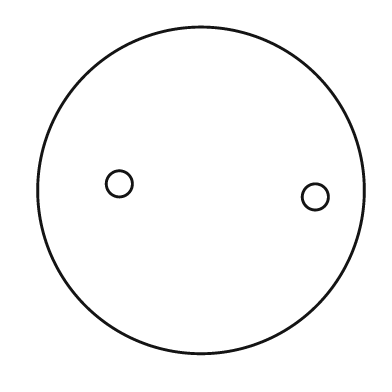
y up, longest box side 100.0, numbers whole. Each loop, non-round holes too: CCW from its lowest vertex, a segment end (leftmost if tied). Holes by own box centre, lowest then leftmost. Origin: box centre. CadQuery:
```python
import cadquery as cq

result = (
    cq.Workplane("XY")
    .moveTo(0.0, 0.0)
    .circle(50.0)
    .moveTo(35.0, -2.0)
    .circle(4.0)
    .moveTo(-25.0, 2.0)
    .circle(4.0)
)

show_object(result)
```